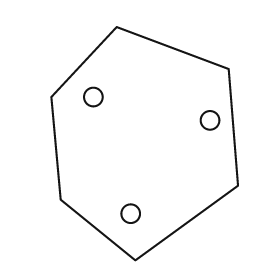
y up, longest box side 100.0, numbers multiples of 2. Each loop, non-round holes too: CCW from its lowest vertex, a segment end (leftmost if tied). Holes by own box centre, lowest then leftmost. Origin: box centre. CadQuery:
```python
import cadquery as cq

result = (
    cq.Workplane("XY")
    .moveTo(-4.0, -50.0)
    .lineTo(40.0, -18.0)
    .lineTo(36.0, 32.0)
    .lineTo(-12.0, 50.0)
    .lineTo(-40.0, 20.0)
    .lineTo(-36.0, -24.0)
    .close()
    .moveTo(-6.0, -30.0)
    .circle(4.0)
    .moveTo(28.0, 10.0)
    .circle(4.0)
    .moveTo(-22.0, 20.0)
    .circle(4.0)
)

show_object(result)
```